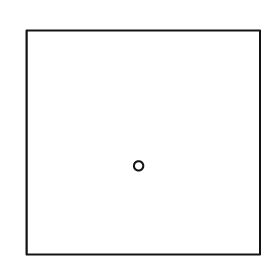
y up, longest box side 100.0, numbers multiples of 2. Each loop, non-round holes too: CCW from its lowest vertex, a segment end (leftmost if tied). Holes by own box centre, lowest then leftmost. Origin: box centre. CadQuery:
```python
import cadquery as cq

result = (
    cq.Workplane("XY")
    .moveTo(-50.0, -48.0)
    .lineTo(50.0, -48.0)
    .lineTo(50.0, 48.0)
    .lineTo(-50.0, 48.0)
    .close()
    .moveTo(-2.0, -10.0)
    .circle(2.0)
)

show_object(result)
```